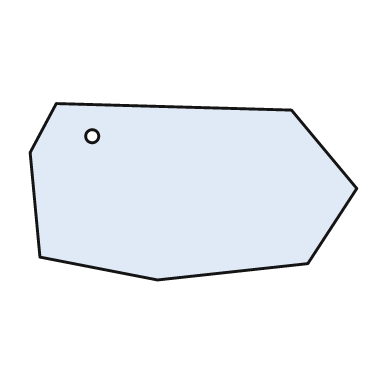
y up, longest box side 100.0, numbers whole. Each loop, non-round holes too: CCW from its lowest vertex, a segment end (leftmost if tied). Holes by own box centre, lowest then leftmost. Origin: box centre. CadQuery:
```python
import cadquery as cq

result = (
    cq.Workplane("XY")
    .moveTo(-11.0, -27.0)
    .lineTo(35.0, -22.0)
    .lineTo(50.0, 1.0)
    .lineTo(30.0, 25.0)
    .lineTo(-42.0, 27.0)
    .lineTo(-50.0, 12.0)
    .lineTo(-47.0, -20.0)
    .close()
    .moveTo(-31.0, 17.0)
    .circle(2.0)
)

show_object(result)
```